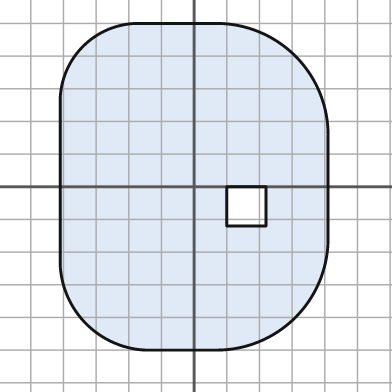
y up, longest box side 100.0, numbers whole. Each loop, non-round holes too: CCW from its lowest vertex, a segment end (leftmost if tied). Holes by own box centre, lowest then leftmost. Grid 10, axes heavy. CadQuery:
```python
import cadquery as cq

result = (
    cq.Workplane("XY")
    .moveTo(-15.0, -50.0)
    .lineTo(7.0, -50.0)
    .threePointArc((31.0, -40.0), (41.0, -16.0))
    .lineTo(41.0, 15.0)
    .threePointArc((31.0, 40.0), (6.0, 50.0))
    .lineTo(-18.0, 50.0)
    .threePointArc((-34.0, 43.0), (-41.0, 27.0))
    .lineTo(-41.0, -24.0)
    .threePointArc((-33.0, -42.0), (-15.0, -50.0))
    .close()
    .moveTo(10.0, -12.0)
    .lineTo(22.0, -12.0)
    .lineTo(22.0, 0.0)
    .lineTo(10.0, 0.0)
    .close()
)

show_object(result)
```